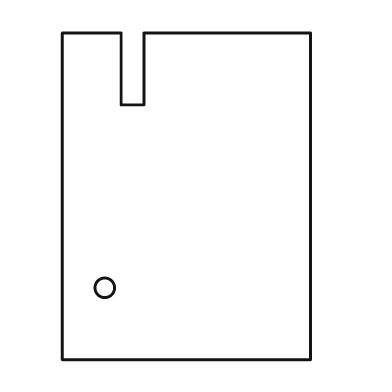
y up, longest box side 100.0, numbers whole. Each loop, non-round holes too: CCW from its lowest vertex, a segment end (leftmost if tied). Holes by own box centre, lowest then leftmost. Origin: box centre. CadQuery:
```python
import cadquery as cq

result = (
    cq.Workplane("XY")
    .moveTo(-38.0, -50.0)
    .lineTo(38.0, -50.0)
    .lineTo(38.0, 50.0)
    .lineTo(-13.0, 50.0)
    .lineTo(-13.0, 28.0)
    .lineTo(-20.0, 28.0)
    .lineTo(-20.0, 50.0)
    .lineTo(-38.0, 50.0)
    .close()
    .moveTo(-25.0, -28.0)
    .circle(3.0)
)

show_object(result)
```